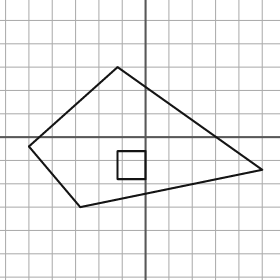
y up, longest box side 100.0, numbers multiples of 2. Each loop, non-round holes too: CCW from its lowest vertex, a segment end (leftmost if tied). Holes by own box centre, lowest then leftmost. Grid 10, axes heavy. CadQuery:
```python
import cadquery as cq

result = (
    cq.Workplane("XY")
    .moveTo(-28.0, -30.0)
    .lineTo(50.0, -14.0)
    .lineTo(-12.0, 30.0)
    .lineTo(-50.0, -4.0)
    .close()
    .moveTo(-12.0, -18.0)
    .lineTo(0.0, -18.0)
    .lineTo(0.0, -6.0)
    .lineTo(-12.0, -6.0)
    .close()
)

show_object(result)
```